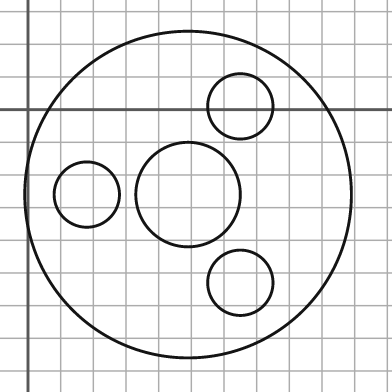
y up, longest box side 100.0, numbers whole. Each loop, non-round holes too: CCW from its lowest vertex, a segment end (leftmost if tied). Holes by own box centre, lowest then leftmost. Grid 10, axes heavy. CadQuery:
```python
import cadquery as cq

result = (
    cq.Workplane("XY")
    .moveTo(49.0, -26.0)
    .circle(50.0)
    .moveTo(65.0, -53.0)
    .circle(10.0)
    .moveTo(18.0, -26.0)
    .circle(10.0)
    .moveTo(49.0, -26.0)
    .circle(16.0)
    .moveTo(65.0, 1.0)
    .circle(10.0)
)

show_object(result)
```